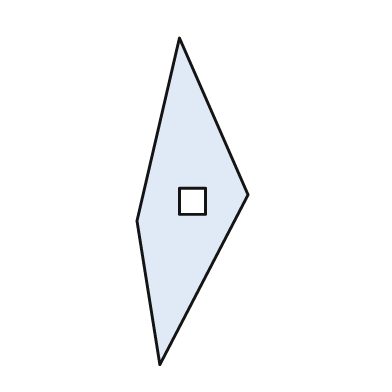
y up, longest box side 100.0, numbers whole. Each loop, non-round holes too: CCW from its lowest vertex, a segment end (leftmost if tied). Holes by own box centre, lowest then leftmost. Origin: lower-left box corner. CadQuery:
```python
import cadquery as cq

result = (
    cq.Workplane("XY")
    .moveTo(7.0, 0.0)
    .lineTo(34.0, 52.0)
    .lineTo(13.0, 100.0)
    .lineTo(0.0, 44.0)
    .close()
    .moveTo(13.0, 46.0)
    .lineTo(21.0, 46.0)
    .lineTo(21.0, 54.0)
    .lineTo(13.0, 54.0)
    .close()
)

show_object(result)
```